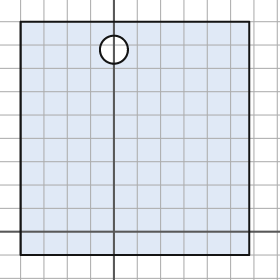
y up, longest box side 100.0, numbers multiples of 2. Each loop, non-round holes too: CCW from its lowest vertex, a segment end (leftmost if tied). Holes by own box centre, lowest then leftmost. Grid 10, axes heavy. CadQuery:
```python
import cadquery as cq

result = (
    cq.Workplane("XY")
    .moveTo(-40.0, -10.0)
    .lineTo(58.0, -10.0)
    .lineTo(58.0, 90.0)
    .lineTo(-40.0, 90.0)
    .close()
    .moveTo(0.0, 78.0)
    .circle(6.0)
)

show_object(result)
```